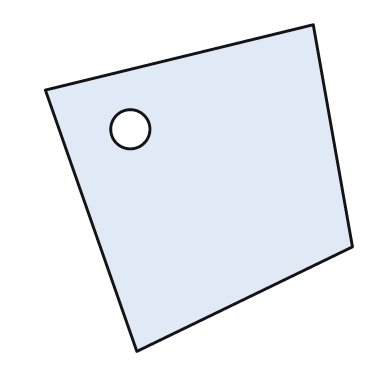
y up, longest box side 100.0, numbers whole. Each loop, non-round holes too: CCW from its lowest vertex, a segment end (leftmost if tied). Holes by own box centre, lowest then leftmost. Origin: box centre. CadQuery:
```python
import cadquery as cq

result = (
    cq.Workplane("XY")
    .moveTo(-19.0, -50.0)
    .lineTo(47.0, -18.0)
    .lineTo(35.0, 50.0)
    .lineTo(-47.0, 30.0)
    .close()
    .moveTo(-21.0, 18.0)
    .circle(6.0)
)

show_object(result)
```